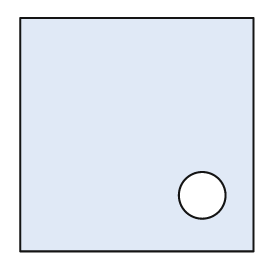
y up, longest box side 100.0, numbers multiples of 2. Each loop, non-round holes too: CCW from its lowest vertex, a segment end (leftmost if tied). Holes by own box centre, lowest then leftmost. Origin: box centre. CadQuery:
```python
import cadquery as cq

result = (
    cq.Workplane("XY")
    .moveTo(-50.0, -50.0)
    .lineTo(50.0, -50.0)
    .lineTo(50.0, 50.0)
    .lineTo(-50.0, 50.0)
    .close()
    .moveTo(28.0, -26.0)
    .circle(10.0)
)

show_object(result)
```